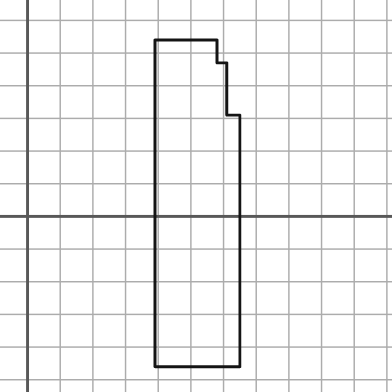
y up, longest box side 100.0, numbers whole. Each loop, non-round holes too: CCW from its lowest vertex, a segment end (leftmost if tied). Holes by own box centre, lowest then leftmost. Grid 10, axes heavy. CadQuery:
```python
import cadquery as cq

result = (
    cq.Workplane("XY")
    .moveTo(39.0, -46.0)
    .lineTo(65.0, -46.0)
    .lineTo(65.0, 31.0)
    .lineTo(61.0, 31.0)
    .lineTo(61.0, 47.0)
    .lineTo(58.0, 47.0)
    .lineTo(58.0, 54.0)
    .lineTo(39.0, 54.0)
    .close()
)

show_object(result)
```